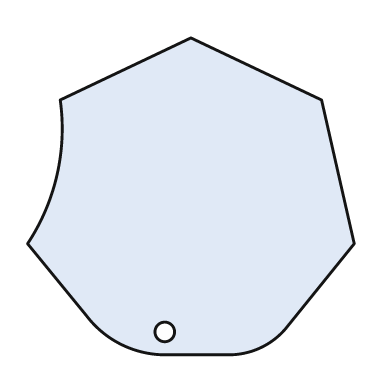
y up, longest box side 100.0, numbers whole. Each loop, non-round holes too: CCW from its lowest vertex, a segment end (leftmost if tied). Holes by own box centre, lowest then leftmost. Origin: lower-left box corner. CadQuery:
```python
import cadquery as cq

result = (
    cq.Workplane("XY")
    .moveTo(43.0, 0.0)
    .lineTo(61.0, 0.0)
    .threePointArc((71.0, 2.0), (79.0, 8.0))
    .lineTo(100.0, 34.0)
    .lineTo(90.0, 78.0)
    .lineTo(50.0, 97.0)
    .lineTo(10.0, 78.0)
    .threePointArc((9.0, 55.0), (0.0, 34.0))
    .lineTo(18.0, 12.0)
    .threePointArc((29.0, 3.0), (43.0, 0.0))
    .close()
    .moveTo(42.0, 7.0)
    .circle(3.0)
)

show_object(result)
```